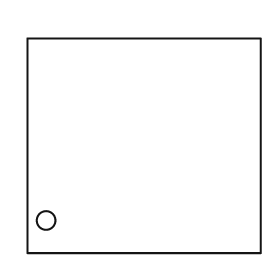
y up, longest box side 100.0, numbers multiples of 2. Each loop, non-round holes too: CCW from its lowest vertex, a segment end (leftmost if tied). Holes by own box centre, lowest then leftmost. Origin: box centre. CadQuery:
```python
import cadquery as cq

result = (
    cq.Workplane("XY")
    .moveTo(-50.0, -46.0)
    .lineTo(50.0, -46.0)
    .lineTo(50.0, 46.0)
    .lineTo(-50.0, 46.0)
    .close()
    .moveTo(-42.0, -32.0)
    .circle(4.0)
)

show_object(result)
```